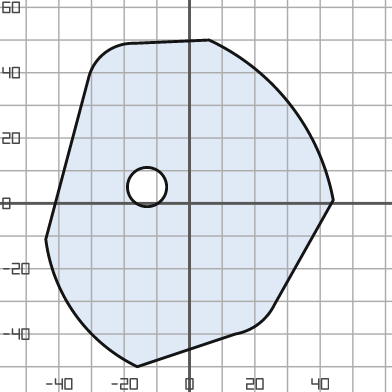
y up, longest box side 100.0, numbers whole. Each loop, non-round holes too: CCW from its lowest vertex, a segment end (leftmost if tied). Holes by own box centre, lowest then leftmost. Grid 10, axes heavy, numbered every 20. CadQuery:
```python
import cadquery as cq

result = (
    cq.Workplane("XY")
    .moveTo(-16.0, -50.0)
    .lineTo(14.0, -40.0)
    .threePointArc((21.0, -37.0), (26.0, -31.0))
    .lineTo(44.0, 1.0)
    .threePointArc((31.0, 30.0), (6.0, 50.0))
    .lineTo(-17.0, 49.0)
    .threePointArc((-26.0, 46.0), (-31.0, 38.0))
    .lineTo(-44.0, -11.0)
    .threePointArc((-35.0, -34.0), (-16.0, -50.0))
    .close()
    .moveTo(-13.0, 5.0)
    .circle(6.0)
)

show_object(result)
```